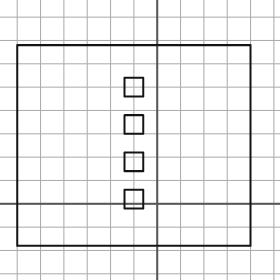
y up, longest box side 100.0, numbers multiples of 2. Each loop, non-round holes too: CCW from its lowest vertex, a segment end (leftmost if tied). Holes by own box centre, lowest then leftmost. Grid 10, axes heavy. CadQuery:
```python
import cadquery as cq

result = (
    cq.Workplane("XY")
    .moveTo(-60.0, -18.0)
    .lineTo(40.0, -18.0)
    .lineTo(40.0, 68.0)
    .lineTo(-60.0, 68.0)
    .close()
    .moveTo(-14.0, -2.0)
    .lineTo(-6.0, -2.0)
    .lineTo(-6.0, 6.0)
    .lineTo(-14.0, 6.0)
    .close()
    .moveTo(-14.0, 14.0)
    .lineTo(-6.0, 14.0)
    .lineTo(-6.0, 22.0)
    .lineTo(-14.0, 22.0)
    .close()
    .moveTo(-14.0, 30.0)
    .lineTo(-6.0, 30.0)
    .lineTo(-6.0, 38.0)
    .lineTo(-14.0, 38.0)
    .close()
    .moveTo(-14.0, 46.0)
    .lineTo(-6.0, 46.0)
    .lineTo(-6.0, 54.0)
    .lineTo(-14.0, 54.0)
    .close()
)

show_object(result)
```